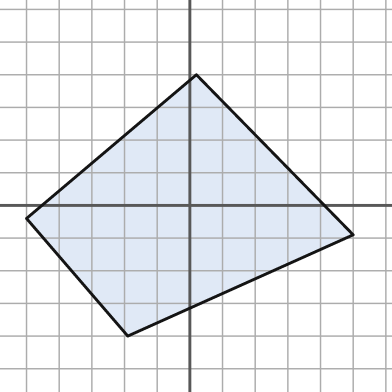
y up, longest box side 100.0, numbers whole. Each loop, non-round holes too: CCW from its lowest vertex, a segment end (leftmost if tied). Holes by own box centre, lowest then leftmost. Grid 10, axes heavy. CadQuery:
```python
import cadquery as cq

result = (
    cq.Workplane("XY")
    .moveTo(-19.0, -40.0)
    .lineTo(50.0, -9.0)
    .lineTo(2.0, 40.0)
    .lineTo(-50.0, -4.0)
    .close()
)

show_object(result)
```